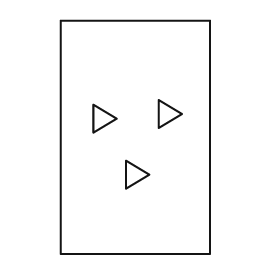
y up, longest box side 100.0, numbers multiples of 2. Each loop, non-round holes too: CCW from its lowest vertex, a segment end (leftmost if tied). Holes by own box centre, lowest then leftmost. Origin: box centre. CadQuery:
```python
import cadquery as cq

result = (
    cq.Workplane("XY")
    .moveTo(-32.0, -50.0)
    .lineTo(32.0, -50.0)
    .lineTo(32.0, 50.0)
    .lineTo(-32.0, 50.0)
    .close()
    .moveTo(-4.0, -22.0)
    .lineTo(6.0, -16.0)
    .lineTo(-4.0, -10.0)
    .close()
    .moveTo(-18.0, 2.0)
    .lineTo(-8.0, 8.0)
    .lineTo(-18.0, 14.0)
    .close()
    .moveTo(10.0, 4.0)
    .lineTo(20.0, 10.0)
    .lineTo(10.0, 16.0)
    .close()
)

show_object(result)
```